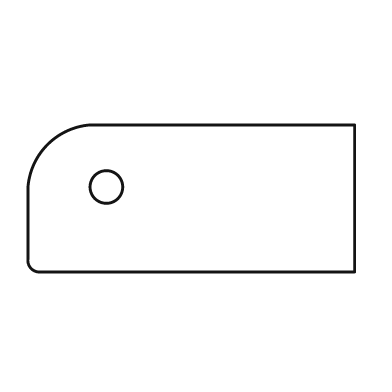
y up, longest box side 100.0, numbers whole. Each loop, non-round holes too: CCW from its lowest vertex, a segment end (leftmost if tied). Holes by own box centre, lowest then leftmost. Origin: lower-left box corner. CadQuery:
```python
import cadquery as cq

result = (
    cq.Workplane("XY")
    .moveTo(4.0, 0.0)
    .lineTo(100.0, 0.0)
    .lineTo(100.0, 45.0)
    .lineTo(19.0, 45.0)
    .threePointArc((6.0, 39.0), (0.0, 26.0))
    .lineTo(0.0, 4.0)
    .threePointArc((1.0, 1.0), (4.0, 0.0))
    .close()
    .moveTo(24.0, 26.0)
    .circle(5.0)
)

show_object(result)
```